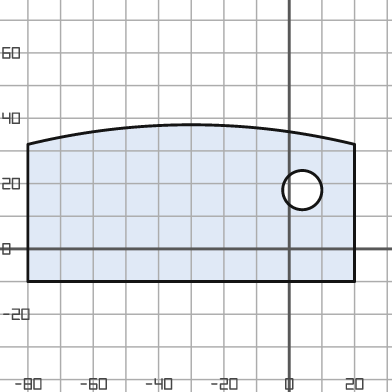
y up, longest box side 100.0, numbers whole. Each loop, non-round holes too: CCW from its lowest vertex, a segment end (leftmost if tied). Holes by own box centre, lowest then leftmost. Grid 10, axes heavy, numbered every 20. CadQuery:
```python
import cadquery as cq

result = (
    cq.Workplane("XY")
    .moveTo(-80.0, -10.0)
    .lineTo(20.0, -10.0)
    .lineTo(20.0, 32.0)
    .threePointArc((-30.0, 38.0), (-80.0, 32.0))
    .close()
    .moveTo(4.0, 18.0)
    .circle(6.0)
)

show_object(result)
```